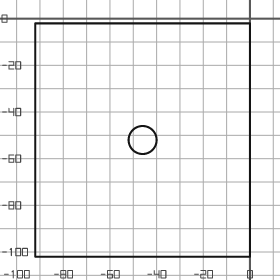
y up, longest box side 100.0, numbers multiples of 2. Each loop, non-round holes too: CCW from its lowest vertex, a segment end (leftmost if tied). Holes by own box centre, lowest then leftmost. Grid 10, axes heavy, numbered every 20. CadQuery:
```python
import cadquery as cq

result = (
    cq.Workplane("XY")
    .moveTo(-92.0, -102.0)
    .lineTo(0.0, -102.0)
    .lineTo(0.0, -2.0)
    .lineTo(-92.0, -2.0)
    .close()
    .moveTo(-46.0, -52.0)
    .circle(6.0)
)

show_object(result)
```